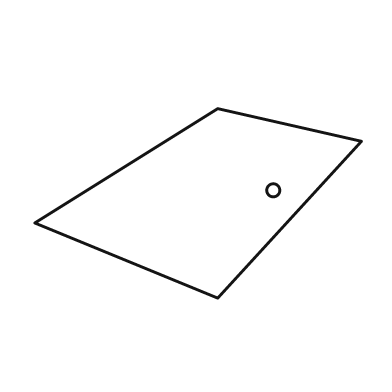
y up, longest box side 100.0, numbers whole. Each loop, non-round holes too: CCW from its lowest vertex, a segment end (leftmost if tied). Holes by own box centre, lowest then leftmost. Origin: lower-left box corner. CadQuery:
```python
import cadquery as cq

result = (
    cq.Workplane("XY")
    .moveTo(56.0, 0.0)
    .lineTo(100.0, 48.0)
    .lineTo(56.0, 58.0)
    .lineTo(0.0, 23.0)
    .close()
    .moveTo(73.0, 33.0)
    .circle(2.0)
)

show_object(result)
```